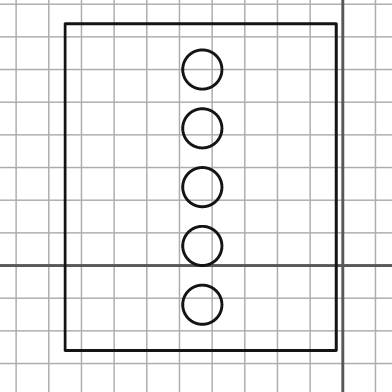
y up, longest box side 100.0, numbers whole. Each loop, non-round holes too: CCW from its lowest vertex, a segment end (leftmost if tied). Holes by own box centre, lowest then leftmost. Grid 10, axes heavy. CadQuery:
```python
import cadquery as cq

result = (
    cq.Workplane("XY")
    .moveTo(-85.0, -26.0)
    .lineTo(-2.0, -26.0)
    .lineTo(-2.0, 74.0)
    .lineTo(-85.0, 74.0)
    .close()
    .moveTo(-43.0, -12.0)
    .circle(6.0)
    .moveTo(-43.0, 6.0)
    .circle(6.0)
    .moveTo(-43.0, 24.0)
    .circle(6.0)
    .moveTo(-43.0, 42.0)
    .circle(6.0)
    .moveTo(-43.0, 60.0)
    .circle(6.0)
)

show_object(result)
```